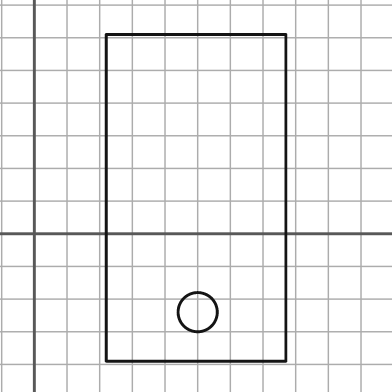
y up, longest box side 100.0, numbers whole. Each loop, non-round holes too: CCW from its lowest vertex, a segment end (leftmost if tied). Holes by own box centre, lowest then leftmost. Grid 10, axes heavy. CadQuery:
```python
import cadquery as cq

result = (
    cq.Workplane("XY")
    .moveTo(22.0, -39.0)
    .lineTo(77.0, -39.0)
    .lineTo(77.0, 61.0)
    .lineTo(22.0, 61.0)
    .close()
    .moveTo(50.0, -24.0)
    .circle(6.0)
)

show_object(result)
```